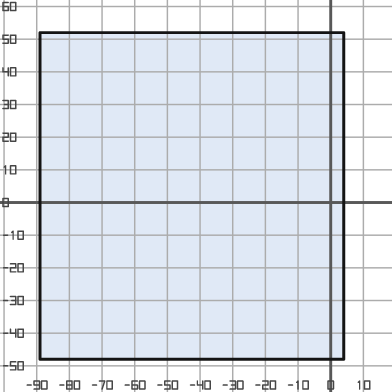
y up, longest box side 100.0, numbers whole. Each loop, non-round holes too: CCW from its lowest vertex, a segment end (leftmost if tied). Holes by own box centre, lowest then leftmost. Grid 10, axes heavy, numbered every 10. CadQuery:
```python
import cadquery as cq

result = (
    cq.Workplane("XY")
    .moveTo(-89.0, -48.0)
    .lineTo(4.0, -48.0)
    .lineTo(4.0, 52.0)
    .lineTo(-89.0, 52.0)
    .close()
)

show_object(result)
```